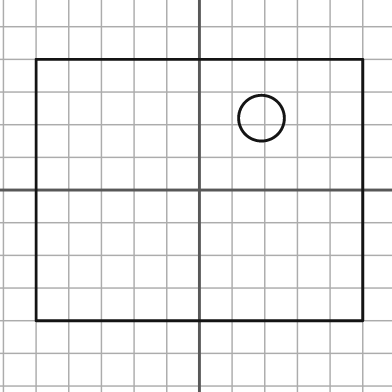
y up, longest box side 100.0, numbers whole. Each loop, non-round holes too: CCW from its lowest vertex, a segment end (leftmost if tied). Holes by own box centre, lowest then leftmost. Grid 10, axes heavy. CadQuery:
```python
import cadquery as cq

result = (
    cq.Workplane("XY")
    .moveTo(-50.0, -40.0)
    .lineTo(50.0, -40.0)
    .lineTo(50.0, 40.0)
    .lineTo(-50.0, 40.0)
    .close()
    .moveTo(19.0, 22.0)
    .circle(7.0)
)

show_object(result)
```